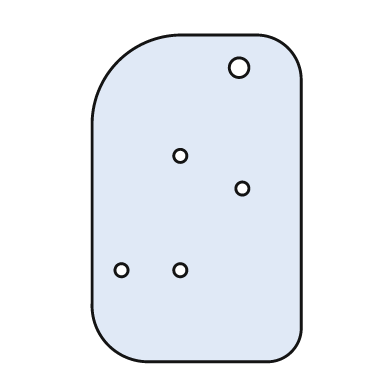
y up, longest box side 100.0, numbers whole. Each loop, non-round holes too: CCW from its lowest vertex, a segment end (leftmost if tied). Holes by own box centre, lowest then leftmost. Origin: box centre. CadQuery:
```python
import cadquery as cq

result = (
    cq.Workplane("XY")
    .moveTo(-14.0, -50.0)
    .lineTo(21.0, -50.0)
    .threePointArc((29.0, -47.0), (32.0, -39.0))
    .lineTo(32.0, 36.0)
    .threePointArc((28.0, 46.0), (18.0, 50.0))
    .lineTo(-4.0, 50.0)
    .threePointArc((-24.0, 42.0), (-32.0, 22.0))
    .lineTo(-32.0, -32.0)
    .threePointArc((-27.0, -45.0), (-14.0, -50.0))
    .close()
    .moveTo(-23.0, -22.0)
    .circle(2.0)
    .moveTo(-5.0, -22.0)
    .circle(2.0)
    .moveTo(14.0, 3.0)
    .circle(2.0)
    .moveTo(-5.0, 13.0)
    .circle(2.0)
    .moveTo(13.0, 40.0)
    .circle(3.0)
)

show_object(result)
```